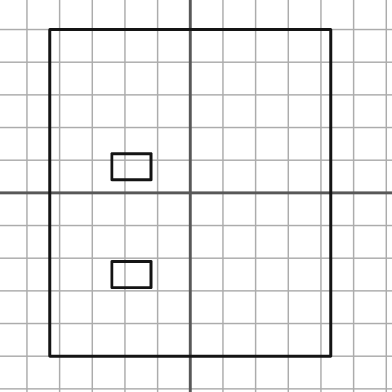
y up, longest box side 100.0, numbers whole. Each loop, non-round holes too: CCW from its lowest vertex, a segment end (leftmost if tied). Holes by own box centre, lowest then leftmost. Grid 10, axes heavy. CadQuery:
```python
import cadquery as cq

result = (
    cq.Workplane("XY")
    .moveTo(-43.0, -50.0)
    .lineTo(43.0, -50.0)
    .lineTo(43.0, 50.0)
    .lineTo(-43.0, 50.0)
    .close()
    .moveTo(-24.0, -29.0)
    .lineTo(-12.0, -29.0)
    .lineTo(-12.0, -21.0)
    .lineTo(-24.0, -21.0)
    .close()
    .moveTo(-24.0, 4.0)
    .lineTo(-12.0, 4.0)
    .lineTo(-12.0, 12.0)
    .lineTo(-24.0, 12.0)
    .close()
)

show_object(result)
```